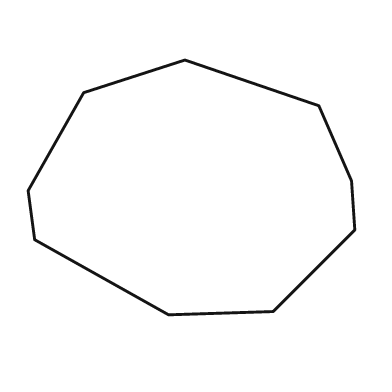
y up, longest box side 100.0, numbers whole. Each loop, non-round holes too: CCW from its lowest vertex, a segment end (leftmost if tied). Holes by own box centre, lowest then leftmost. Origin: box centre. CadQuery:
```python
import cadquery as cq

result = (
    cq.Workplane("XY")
    .moveTo(-7.0, -39.0)
    .lineTo(25.0, -38.0)
    .lineTo(50.0, -13.0)
    .lineTo(49.0, 2.0)
    .lineTo(39.0, 25.0)
    .lineTo(-2.0, 39.0)
    .lineTo(-33.0, 29.0)
    .lineTo(-50.0, -1.0)
    .lineTo(-48.0, -16.0)
    .close()
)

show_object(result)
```